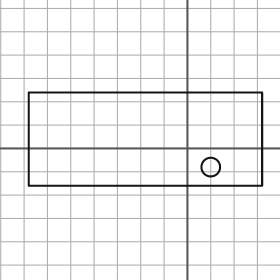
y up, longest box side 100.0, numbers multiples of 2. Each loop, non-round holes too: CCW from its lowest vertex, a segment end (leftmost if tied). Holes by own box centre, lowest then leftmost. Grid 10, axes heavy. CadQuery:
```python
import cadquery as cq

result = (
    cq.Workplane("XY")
    .moveTo(-68.0, -16.0)
    .lineTo(32.0, -16.0)
    .lineTo(32.0, 24.0)
    .lineTo(-68.0, 24.0)
    .close()
    .moveTo(10.0, -8.0)
    .circle(4.0)
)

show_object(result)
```